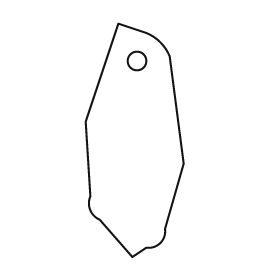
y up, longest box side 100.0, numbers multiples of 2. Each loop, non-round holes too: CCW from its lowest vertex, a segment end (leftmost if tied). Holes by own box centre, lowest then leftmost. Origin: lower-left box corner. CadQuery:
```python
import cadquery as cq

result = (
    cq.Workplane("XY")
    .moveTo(20.0, 0.0)
    .lineTo(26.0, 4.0)
    .threePointArc((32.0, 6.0), (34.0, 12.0))
    .lineTo(42.0, 40.0)
    .lineTo(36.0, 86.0)
    .threePointArc((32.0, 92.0), (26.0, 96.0))
    .lineTo(14.0, 100.0)
    .lineTo(0.0, 58.0)
    .lineTo(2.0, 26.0)
    .threePointArc((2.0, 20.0), (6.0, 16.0))
    .close()
    .moveTo(22.0, 84.0)
    .circle(4.0)
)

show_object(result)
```